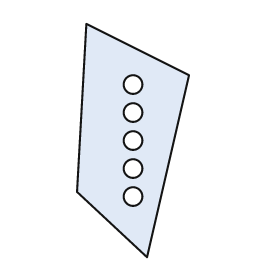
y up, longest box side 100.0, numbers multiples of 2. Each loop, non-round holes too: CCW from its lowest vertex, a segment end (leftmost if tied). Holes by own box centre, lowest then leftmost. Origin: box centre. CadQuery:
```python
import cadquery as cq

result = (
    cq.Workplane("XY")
    .moveTo(6.0, -50.0)
    .lineTo(24.0, 28.0)
    .lineTo(-20.0, 50.0)
    .lineTo(-24.0, -22.0)
    .close()
    .moveTo(0.0, -24.0)
    .circle(4.0)
    .moveTo(0.0, -12.0)
    .circle(4.0)
    .moveTo(0.0, 0.0)
    .circle(4.0)
    .moveTo(0.0, 12.0)
    .circle(4.0)
    .moveTo(0.0, 24.0)
    .circle(4.0)
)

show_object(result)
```